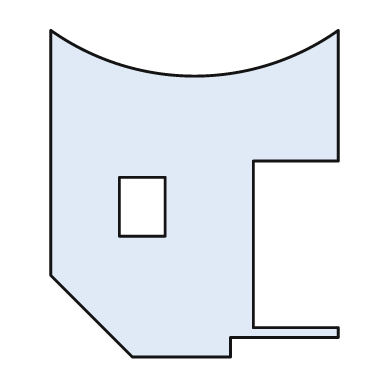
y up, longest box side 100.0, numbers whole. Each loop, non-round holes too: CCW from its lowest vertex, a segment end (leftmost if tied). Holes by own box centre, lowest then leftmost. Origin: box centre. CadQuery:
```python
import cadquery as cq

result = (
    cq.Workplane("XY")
    .moveTo(-19.0, -50.0)
    .lineTo(11.0, -50.0)
    .lineTo(11.0, -44.0)
    .lineTo(44.0, -44.0)
    .lineTo(44.0, -41.0)
    .lineTo(18.0, -41.0)
    .lineTo(18.0, 10.0)
    .lineTo(44.0, 10.0)
    .lineTo(44.0, 50.0)
    .threePointArc((0.0, 36.0), (-44.0, 50.0))
    .lineTo(-44.0, -25.0)
    .close()
    .moveTo(-23.0, -13.0)
    .lineTo(-9.0, -13.0)
    .lineTo(-9.0, 5.0)
    .lineTo(-23.0, 5.0)
    .close()
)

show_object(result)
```